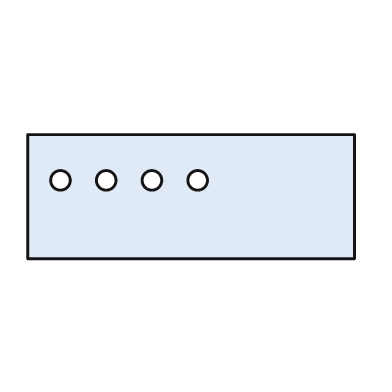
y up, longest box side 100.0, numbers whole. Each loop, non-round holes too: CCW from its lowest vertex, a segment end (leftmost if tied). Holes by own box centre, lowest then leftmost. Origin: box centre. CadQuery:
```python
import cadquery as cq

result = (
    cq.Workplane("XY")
    .moveTo(-50.0, -19.0)
    .lineTo(50.0, -19.0)
    .lineTo(50.0, 19.0)
    .lineTo(-50.0, 19.0)
    .close()
    .moveTo(-40.0, 5.0)
    .circle(3.0)
    .moveTo(-26.0, 5.0)
    .circle(3.0)
    .moveTo(-12.0, 5.0)
    .circle(3.0)
    .moveTo(2.0, 5.0)
    .circle(3.0)
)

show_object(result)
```